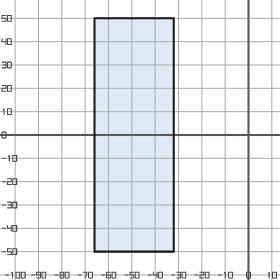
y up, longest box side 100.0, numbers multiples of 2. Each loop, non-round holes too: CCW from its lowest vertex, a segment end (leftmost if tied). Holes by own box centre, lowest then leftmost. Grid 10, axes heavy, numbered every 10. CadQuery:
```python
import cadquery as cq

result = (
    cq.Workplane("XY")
    .moveTo(-66.0, -50.0)
    .lineTo(-32.0, -50.0)
    .lineTo(-32.0, 50.0)
    .lineTo(-66.0, 50.0)
    .close()
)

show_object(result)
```